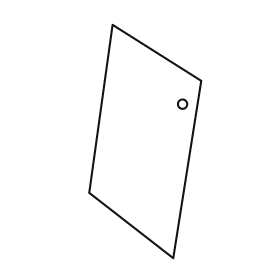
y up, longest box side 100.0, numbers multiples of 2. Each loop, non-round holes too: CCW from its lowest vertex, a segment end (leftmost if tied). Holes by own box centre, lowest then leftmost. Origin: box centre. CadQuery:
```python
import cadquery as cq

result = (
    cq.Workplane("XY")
    .moveTo(12.0, -50.0)
    .lineTo(24.0, 26.0)
    .lineTo(-14.0, 50.0)
    .lineTo(-24.0, -22.0)
    .close()
    .moveTo(16.0, 16.0)
    .circle(2.0)
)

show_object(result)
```